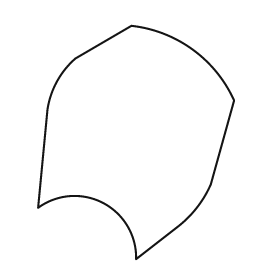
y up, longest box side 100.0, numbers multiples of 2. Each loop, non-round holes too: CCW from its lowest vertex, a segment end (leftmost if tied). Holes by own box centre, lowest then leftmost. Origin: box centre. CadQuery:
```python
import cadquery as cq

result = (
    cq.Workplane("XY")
    .moveTo(0.0, -50.0)
    .lineTo(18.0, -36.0)
    .threePointArc((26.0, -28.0), (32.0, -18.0))
    .lineTo(42.0, 18.0)
    .threePointArc((24.0, 40.0), (-2.0, 50.0))
    .lineTo(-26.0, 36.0)
    .threePointArc((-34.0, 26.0), (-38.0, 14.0))
    .lineTo(-42.0, -28.0)
    .threePointArc((-14.0, -26.0), (0.0, -50.0))
    .close()
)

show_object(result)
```